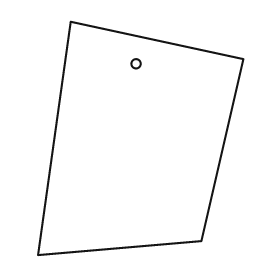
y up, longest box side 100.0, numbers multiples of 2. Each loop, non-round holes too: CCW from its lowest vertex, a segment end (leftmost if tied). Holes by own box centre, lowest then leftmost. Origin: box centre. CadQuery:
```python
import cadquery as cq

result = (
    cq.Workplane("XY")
    .moveTo(-44.0, -50.0)
    .lineTo(26.0, -44.0)
    .lineTo(44.0, 34.0)
    .lineTo(-30.0, 50.0)
    .close()
    .moveTo(-2.0, 32.0)
    .circle(2.0)
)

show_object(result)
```